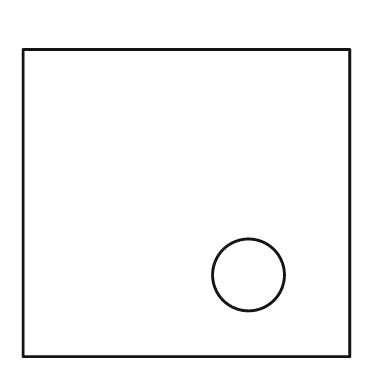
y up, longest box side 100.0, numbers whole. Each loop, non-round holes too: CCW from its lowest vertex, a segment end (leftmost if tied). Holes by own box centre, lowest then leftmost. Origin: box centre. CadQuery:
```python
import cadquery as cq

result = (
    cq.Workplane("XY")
    .moveTo(-50.0, -47.0)
    .lineTo(50.0, -47.0)
    .lineTo(50.0, 47.0)
    .lineTo(-50.0, 47.0)
    .close()
    .moveTo(19.0, -22.0)
    .circle(11.0)
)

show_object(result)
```